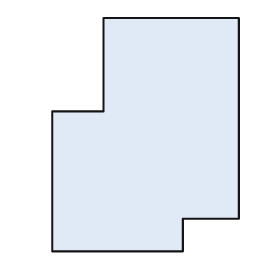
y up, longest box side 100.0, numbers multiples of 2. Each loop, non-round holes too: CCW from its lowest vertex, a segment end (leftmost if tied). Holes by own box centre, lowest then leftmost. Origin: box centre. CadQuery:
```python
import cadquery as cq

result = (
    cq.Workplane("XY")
    .moveTo(-40.0, -50.0)
    .lineTo(16.0, -50.0)
    .lineTo(16.0, -36.0)
    .lineTo(40.0, -36.0)
    .lineTo(40.0, 50.0)
    .lineTo(-18.0, 50.0)
    .lineTo(-18.0, 10.0)
    .lineTo(-40.0, 10.0)
    .close()
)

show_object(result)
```